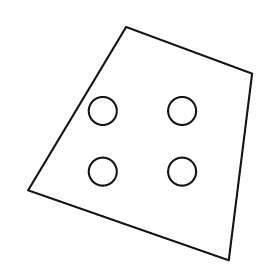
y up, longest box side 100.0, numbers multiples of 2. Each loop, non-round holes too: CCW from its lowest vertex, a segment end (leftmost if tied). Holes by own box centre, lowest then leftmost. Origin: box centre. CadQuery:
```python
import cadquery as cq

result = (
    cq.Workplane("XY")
    .moveTo(38.0, -50.0)
    .lineTo(48.0, 30.0)
    .lineTo(-6.0, 50.0)
    .lineTo(-48.0, -20.0)
    .close()
    .moveTo(-16.0, -12.0)
    .circle(6.0)
    .moveTo(18.0, -12.0)
    .circle(6.0)
    .moveTo(-16.0, 14.0)
    .circle(6.0)
    .moveTo(18.0, 14.0)
    .circle(6.0)
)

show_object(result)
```